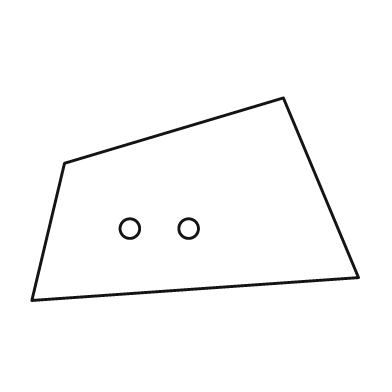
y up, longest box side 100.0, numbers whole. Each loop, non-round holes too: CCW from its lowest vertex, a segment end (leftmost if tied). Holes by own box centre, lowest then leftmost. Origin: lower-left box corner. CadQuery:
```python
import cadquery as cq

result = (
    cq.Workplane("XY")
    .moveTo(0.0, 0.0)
    .lineTo(100.0, 7.0)
    .lineTo(77.0, 62.0)
    .lineTo(10.0, 42.0)
    .close()
    .moveTo(30.0, 22.0)
    .circle(3.0)
    .moveTo(48.0, 22.0)
    .circle(3.0)
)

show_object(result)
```